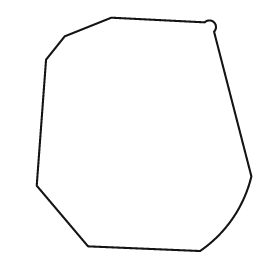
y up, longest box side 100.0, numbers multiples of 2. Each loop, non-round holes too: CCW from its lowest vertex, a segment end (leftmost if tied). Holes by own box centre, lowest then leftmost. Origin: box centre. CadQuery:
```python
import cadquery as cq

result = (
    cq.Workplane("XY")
    .moveTo(24.0, -50.0)
    .threePointArc((38.0, -36.0), (46.0, -18.0))
    .lineTo(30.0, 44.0)
    .threePointArc((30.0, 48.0), (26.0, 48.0))
    .lineTo(-14.0, 50.0)
    .lineTo(-34.0, 42.0)
    .lineTo(-42.0, 32.0)
    .lineTo(-46.0, -22.0)
    .lineTo(-24.0, -48.0)
    .close()
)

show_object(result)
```